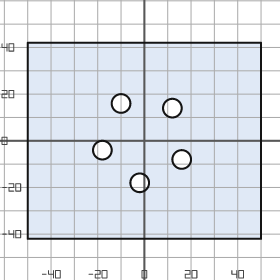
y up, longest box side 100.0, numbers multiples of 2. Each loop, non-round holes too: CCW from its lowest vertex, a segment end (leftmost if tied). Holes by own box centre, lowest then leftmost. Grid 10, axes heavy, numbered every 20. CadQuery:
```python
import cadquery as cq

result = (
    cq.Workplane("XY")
    .moveTo(-50.0, -42.0)
    .lineTo(50.0, -42.0)
    .lineTo(50.0, 42.0)
    .lineTo(-50.0, 42.0)
    .close()
    .moveTo(-2.0, -18.0)
    .circle(4.0)
    .moveTo(16.0, -8.0)
    .circle(4.0)
    .moveTo(-18.0, -4.0)
    .circle(4.0)
    .moveTo(12.0, 14.0)
    .circle(4.0)
    .moveTo(-10.0, 16.0)
    .circle(4.0)
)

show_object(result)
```